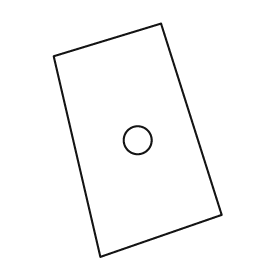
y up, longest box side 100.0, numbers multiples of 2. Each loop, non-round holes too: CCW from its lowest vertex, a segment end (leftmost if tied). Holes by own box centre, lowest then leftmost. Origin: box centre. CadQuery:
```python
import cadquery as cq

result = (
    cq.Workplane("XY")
    .moveTo(-16.0, -50.0)
    .lineTo(36.0, -32.0)
    .lineTo(10.0, 50.0)
    .lineTo(-36.0, 36.0)
    .close()
    .moveTo(0.0, 0.0)
    .circle(6.0)
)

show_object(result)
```